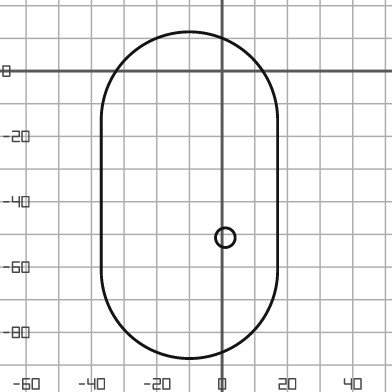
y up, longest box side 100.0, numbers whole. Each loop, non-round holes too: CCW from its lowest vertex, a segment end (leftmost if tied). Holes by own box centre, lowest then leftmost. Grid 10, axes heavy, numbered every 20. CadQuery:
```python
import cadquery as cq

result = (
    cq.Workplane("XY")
    .moveTo(-37.0, -61.0)
    .threePointArc((-10.0, -88.0), (17.0, -61.0))
    .lineTo(17.0, -15.0)
    .threePointArc((-10.0, 12.0), (-37.0, -15.0))
    .close()
    .moveTo(1.0, -51.0)
    .circle(3.0)
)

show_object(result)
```